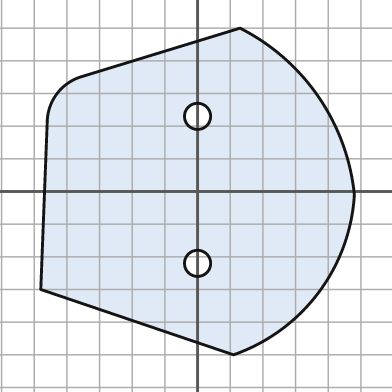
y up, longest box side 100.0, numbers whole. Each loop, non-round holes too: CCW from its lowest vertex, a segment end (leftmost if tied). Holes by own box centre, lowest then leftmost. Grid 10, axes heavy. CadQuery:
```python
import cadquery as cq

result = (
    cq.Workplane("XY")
    .moveTo(11.0, -50.0)
    .threePointArc((37.0, -31.0), (48.0, -1.0))
    .threePointArc((37.0, 29.0), (13.0, 50.0))
    .lineTo(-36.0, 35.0)
    .threePointArc((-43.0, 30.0), (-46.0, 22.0))
    .lineTo(-48.0, -30.0)
    .close()
    .moveTo(0.0, -22.0)
    .circle(4.0)
    .moveTo(0.0, 23.0)
    .circle(4.0)
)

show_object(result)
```